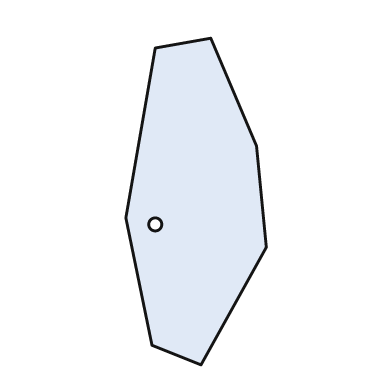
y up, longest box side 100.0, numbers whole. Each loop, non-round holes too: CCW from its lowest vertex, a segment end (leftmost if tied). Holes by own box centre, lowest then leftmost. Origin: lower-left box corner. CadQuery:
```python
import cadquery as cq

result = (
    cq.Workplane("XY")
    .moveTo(23.0, 0.0)
    .lineTo(43.0, 36.0)
    .lineTo(40.0, 67.0)
    .lineTo(26.0, 100.0)
    .lineTo(9.0, 97.0)
    .lineTo(0.0, 45.0)
    .lineTo(8.0, 6.0)
    .close()
    .moveTo(9.0, 43.0)
    .circle(2.0)
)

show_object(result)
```